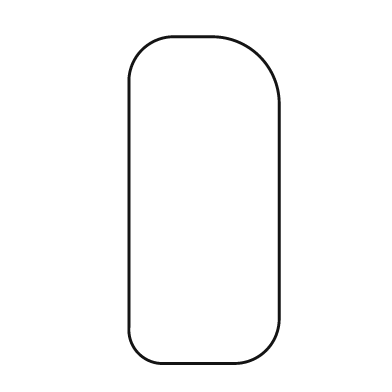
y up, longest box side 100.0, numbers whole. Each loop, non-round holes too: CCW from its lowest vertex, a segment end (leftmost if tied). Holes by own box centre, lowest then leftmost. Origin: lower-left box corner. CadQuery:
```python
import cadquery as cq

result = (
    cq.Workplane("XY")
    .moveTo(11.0, 0.0)
    .lineTo(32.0, 0.0)
    .threePointArc((42.0, 4.0), (46.0, 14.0))
    .lineTo(46.0, 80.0)
    .threePointArc((40.0, 94.0), (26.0, 100.0))
    .lineTo(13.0, 100.0)
    .threePointArc((4.0, 96.0), (0.0, 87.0))
    .lineTo(0.0, 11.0)
    .threePointArc((3.0, 3.0), (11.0, 0.0))
    .close()
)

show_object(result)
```